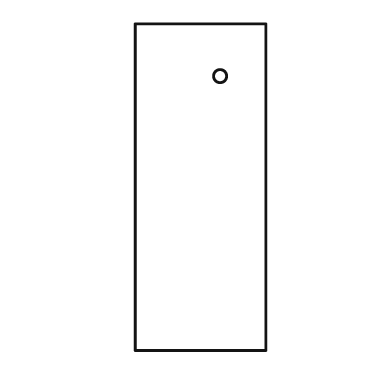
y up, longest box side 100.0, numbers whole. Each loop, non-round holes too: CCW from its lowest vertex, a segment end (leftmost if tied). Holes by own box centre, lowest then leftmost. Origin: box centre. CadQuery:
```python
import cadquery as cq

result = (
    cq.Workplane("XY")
    .moveTo(-20.0, -50.0)
    .lineTo(20.0, -50.0)
    .lineTo(20.0, 50.0)
    .lineTo(-20.0, 50.0)
    .close()
    .moveTo(6.0, 34.0)
    .circle(2.0)
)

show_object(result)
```